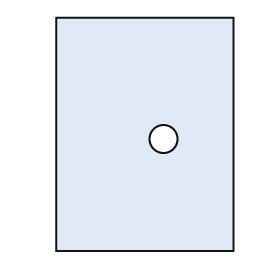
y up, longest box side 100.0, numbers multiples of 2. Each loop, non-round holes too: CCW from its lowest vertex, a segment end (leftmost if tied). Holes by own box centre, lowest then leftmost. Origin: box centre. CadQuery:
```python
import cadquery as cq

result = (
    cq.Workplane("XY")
    .moveTo(-38.0, -50.0)
    .lineTo(38.0, -50.0)
    .lineTo(38.0, 50.0)
    .lineTo(-38.0, 50.0)
    .close()
    .moveTo(8.0, -2.0)
    .circle(6.0)
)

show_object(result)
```